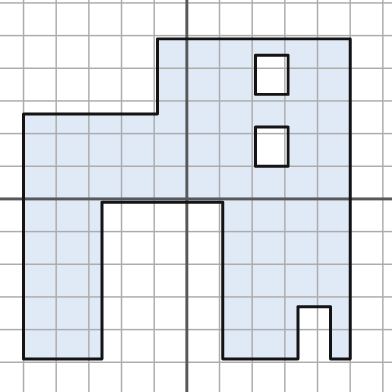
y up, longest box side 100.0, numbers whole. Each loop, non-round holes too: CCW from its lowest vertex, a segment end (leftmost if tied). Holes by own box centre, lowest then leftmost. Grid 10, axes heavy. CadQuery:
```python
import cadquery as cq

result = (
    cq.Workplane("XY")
    .moveTo(-50.0, -49.0)
    .lineTo(-26.0, -49.0)
    .lineTo(-26.0, -1.0)
    .lineTo(11.0, -1.0)
    .lineTo(11.0, -49.0)
    .lineTo(34.0, -49.0)
    .lineTo(34.0, -33.0)
    .lineTo(44.0, -33.0)
    .lineTo(44.0, -49.0)
    .lineTo(50.0, -49.0)
    .lineTo(50.0, 49.0)
    .lineTo(-9.0, 49.0)
    .lineTo(-9.0, 26.0)
    .lineTo(-50.0, 26.0)
    .close()
    .moveTo(21.0, 10.0)
    .lineTo(31.0, 10.0)
    .lineTo(31.0, 22.0)
    .lineTo(21.0, 22.0)
    .close()
    .moveTo(21.0, 32.0)
    .lineTo(31.0, 32.0)
    .lineTo(31.0, 44.0)
    .lineTo(21.0, 44.0)
    .close()
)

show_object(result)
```